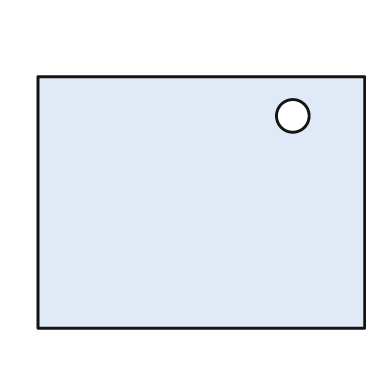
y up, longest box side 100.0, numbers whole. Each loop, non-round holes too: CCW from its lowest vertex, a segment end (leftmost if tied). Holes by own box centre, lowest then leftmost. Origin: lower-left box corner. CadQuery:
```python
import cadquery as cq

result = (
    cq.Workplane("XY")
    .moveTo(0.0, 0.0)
    .lineTo(100.0, 0.0)
    .lineTo(100.0, 77.0)
    .lineTo(0.0, 77.0)
    .close()
    .moveTo(78.0, 65.0)
    .circle(5.0)
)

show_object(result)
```